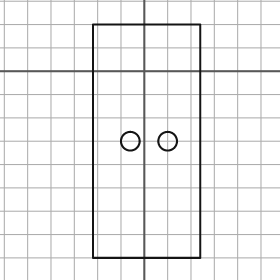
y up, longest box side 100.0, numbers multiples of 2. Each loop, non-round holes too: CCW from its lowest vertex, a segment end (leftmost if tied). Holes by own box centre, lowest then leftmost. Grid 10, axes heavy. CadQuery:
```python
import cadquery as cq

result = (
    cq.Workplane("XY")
    .moveTo(-22.0, -80.0)
    .lineTo(24.0, -80.0)
    .lineTo(24.0, 20.0)
    .lineTo(-22.0, 20.0)
    .close()
    .moveTo(-6.0, -30.0)
    .circle(4.0)
    .moveTo(10.0, -30.0)
    .circle(4.0)
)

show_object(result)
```